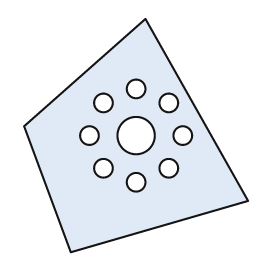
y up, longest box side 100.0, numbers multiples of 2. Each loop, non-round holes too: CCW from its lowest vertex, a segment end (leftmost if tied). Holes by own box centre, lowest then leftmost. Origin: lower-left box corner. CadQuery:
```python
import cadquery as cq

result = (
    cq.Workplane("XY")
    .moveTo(20.0, 0.0)
    .lineTo(96.0, 22.0)
    .lineTo(52.0, 100.0)
    .lineTo(0.0, 54.0)
    .close()
    .moveTo(48.0, 30.0)
    .circle(4.0)
    .moveTo(34.0, 36.0)
    .circle(4.0)
    .moveTo(62.0, 36.0)
    .circle(4.0)
    .moveTo(28.0, 50.0)
    .circle(4.0)
    .moveTo(48.0, 50.0)
    .circle(8.0)
    .moveTo(68.0, 50.0)
    .circle(4.0)
    .moveTo(34.0, 64.0)
    .circle(4.0)
    .moveTo(62.0, 64.0)
    .circle(4.0)
    .moveTo(48.0, 70.0)
    .circle(4.0)
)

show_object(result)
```